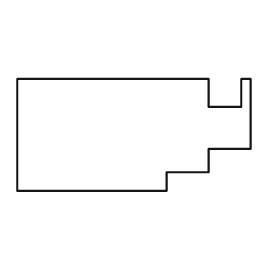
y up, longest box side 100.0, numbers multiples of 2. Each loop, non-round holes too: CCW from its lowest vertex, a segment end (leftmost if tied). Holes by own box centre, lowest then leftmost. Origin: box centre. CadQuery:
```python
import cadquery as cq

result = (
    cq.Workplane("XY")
    .moveTo(-50.0, -24.0)
    .lineTo(14.0, -24.0)
    .lineTo(14.0, -16.0)
    .lineTo(32.0, -16.0)
    .lineTo(32.0, -6.0)
    .lineTo(50.0, -6.0)
    .lineTo(50.0, 24.0)
    .lineTo(46.0, 24.0)
    .lineTo(46.0, 12.0)
    .lineTo(32.0, 12.0)
    .lineTo(32.0, 24.0)
    .lineTo(-50.0, 24.0)
    .close()
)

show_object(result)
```